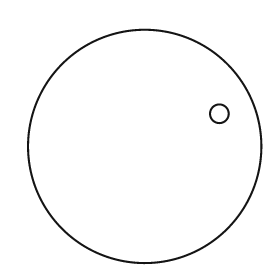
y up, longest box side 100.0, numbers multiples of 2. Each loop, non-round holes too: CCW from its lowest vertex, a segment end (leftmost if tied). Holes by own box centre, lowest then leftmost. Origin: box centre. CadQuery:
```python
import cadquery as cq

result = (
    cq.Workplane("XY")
    .moveTo(0.0, 0.0)
    .circle(50.0)
    .moveTo(32.0, 14.0)
    .circle(4.0)
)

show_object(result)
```